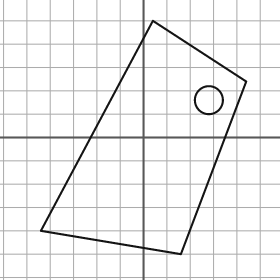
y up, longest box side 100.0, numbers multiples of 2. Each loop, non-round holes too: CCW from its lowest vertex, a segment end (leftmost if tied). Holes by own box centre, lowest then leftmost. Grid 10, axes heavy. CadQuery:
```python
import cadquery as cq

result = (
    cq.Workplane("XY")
    .moveTo(16.0, -50.0)
    .lineTo(44.0, 24.0)
    .lineTo(4.0, 50.0)
    .lineTo(-44.0, -40.0)
    .close()
    .moveTo(28.0, 16.0)
    .circle(6.0)
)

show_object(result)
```